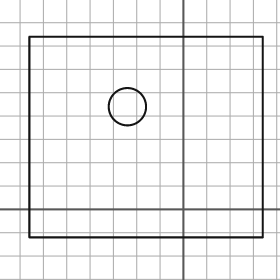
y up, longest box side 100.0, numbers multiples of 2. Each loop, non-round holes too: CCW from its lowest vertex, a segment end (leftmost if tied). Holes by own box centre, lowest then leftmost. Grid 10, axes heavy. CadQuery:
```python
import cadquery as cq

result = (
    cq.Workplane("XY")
    .moveTo(-66.0, -12.0)
    .lineTo(34.0, -12.0)
    .lineTo(34.0, 74.0)
    .lineTo(-66.0, 74.0)
    .close()
    .moveTo(-24.0, 44.0)
    .circle(8.0)
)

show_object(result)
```